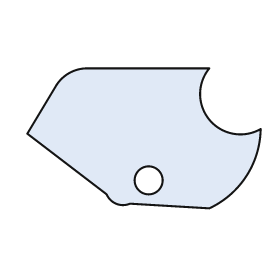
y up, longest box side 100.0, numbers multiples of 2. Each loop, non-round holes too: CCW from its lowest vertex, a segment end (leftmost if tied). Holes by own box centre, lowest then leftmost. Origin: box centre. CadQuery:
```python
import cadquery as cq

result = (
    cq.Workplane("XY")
    .moveTo(28.0, -30.0)
    .threePointArc((44.0, -16.0), (50.0, 4.0))
    .threePointArc((28.0, 8.0), (28.0, 30.0))
    .lineTo(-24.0, 30.0)
    .threePointArc((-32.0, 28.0), (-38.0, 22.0))
    .lineTo(-50.0, 2.0)
    .lineTo(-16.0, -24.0)
    .threePointArc((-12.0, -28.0), (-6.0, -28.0))
    .close()
    .moveTo(2.0, -18.0)
    .circle(6.0)
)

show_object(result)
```